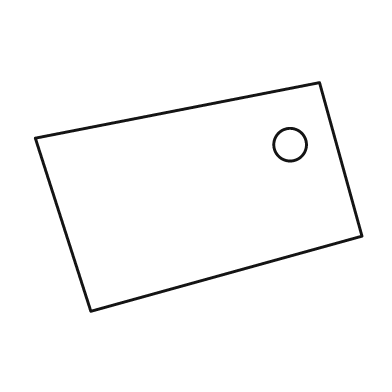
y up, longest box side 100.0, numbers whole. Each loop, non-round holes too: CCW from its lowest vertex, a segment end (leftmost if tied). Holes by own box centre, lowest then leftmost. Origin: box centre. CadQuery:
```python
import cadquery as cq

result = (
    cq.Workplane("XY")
    .moveTo(-33.0, -35.0)
    .lineTo(50.0, -12.0)
    .lineTo(37.0, 35.0)
    .lineTo(-50.0, 18.0)
    .close()
    .moveTo(28.0, 16.0)
    .circle(5.0)
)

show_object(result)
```